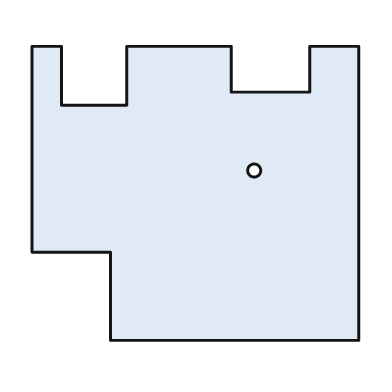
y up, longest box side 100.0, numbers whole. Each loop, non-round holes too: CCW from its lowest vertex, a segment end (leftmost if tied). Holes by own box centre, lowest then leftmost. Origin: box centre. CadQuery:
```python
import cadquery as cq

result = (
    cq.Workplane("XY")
    .moveTo(-26.0, -45.0)
    .lineTo(50.0, -45.0)
    .lineTo(50.0, 45.0)
    .lineTo(35.0, 45.0)
    .lineTo(35.0, 31.0)
    .lineTo(11.0, 31.0)
    .lineTo(11.0, 45.0)
    .lineTo(-21.0, 45.0)
    .lineTo(-21.0, 27.0)
    .lineTo(-41.0, 27.0)
    .lineTo(-41.0, 45.0)
    .lineTo(-50.0, 45.0)
    .lineTo(-50.0, -18.0)
    .lineTo(-26.0, -18.0)
    .close()
    .moveTo(18.0, 7.0)
    .circle(2.0)
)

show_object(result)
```